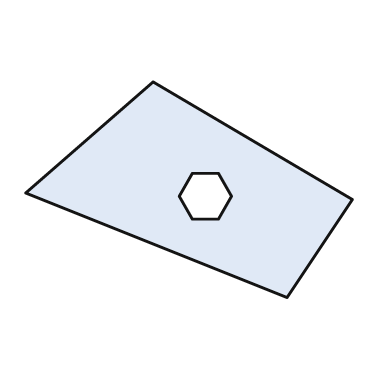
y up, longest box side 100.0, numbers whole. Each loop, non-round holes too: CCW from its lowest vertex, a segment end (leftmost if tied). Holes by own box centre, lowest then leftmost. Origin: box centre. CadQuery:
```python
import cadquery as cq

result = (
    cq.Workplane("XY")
    .moveTo(30.0, -33.0)
    .lineTo(50.0, -3.0)
    .lineTo(-11.0, 33.0)
    .lineTo(-50.0, -1.0)
    .close()
    .moveTo(1.0, -9.0)
    .lineTo(9.0, -9.0)
    .lineTo(13.0, -2.0)
    .lineTo(9.0, 5.0)
    .lineTo(1.0, 5.0)
    .lineTo(-3.0, -2.0)
    .close()
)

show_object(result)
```